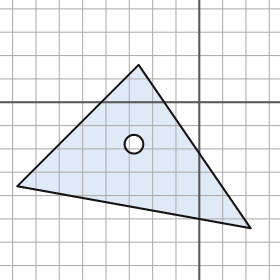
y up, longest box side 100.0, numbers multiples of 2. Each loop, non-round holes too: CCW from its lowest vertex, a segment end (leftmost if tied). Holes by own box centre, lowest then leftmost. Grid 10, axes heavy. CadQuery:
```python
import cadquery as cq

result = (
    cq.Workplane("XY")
    .moveTo(22.0, -54.0)
    .lineTo(-26.0, 16.0)
    .lineTo(-78.0, -36.0)
    .close()
    .moveTo(-28.0, -18.0)
    .circle(4.0)
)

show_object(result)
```